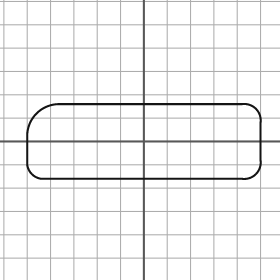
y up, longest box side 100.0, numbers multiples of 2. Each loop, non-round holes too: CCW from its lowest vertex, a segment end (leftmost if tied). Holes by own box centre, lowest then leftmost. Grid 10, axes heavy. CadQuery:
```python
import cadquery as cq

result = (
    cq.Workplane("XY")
    .moveTo(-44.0, -16.0)
    .lineTo(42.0, -16.0)
    .threePointArc((48.0, -14.0), (50.0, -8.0))
    .lineTo(50.0, 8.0)
    .threePointArc((48.0, 14.0), (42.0, 16.0))
    .lineTo(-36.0, 16.0)
    .threePointArc((-46.0, 12.0), (-50.0, 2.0))
    .lineTo(-50.0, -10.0)
    .threePointArc((-48.0, -14.0), (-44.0, -16.0))
    .close()
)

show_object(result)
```